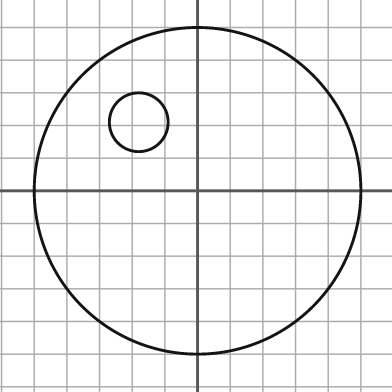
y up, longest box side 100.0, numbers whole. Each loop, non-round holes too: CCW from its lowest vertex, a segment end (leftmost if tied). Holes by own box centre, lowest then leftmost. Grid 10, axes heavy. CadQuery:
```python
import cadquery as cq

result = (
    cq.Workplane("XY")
    .moveTo(0.0, 0.0)
    .circle(50.0)
    .moveTo(-18.0, 21.0)
    .circle(9.0)
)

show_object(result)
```